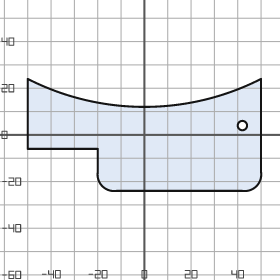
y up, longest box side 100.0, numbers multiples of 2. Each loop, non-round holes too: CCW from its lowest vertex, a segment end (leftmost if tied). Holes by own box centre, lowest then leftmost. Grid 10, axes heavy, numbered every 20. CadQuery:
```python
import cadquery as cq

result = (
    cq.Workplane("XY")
    .moveTo(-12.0, -24.0)
    .lineTo(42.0, -24.0)
    .threePointArc((48.0, -22.0), (50.0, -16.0))
    .lineTo(50.0, 24.0)
    .threePointArc((0.0, 12.0), (-50.0, 24.0))
    .lineTo(-50.0, -6.0)
    .lineTo(-20.0, -6.0)
    .lineTo(-20.0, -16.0)
    .threePointArc((-18.0, -22.0), (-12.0, -24.0))
    .close()
    .moveTo(42.0, 4.0)
    .circle(2.0)
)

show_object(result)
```